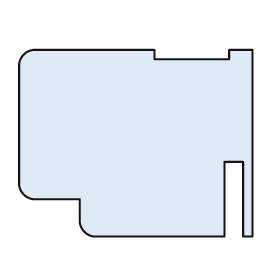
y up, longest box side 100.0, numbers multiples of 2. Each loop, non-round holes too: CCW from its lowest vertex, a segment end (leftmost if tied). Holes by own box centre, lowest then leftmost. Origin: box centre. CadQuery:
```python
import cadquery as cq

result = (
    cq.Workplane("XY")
    .moveTo(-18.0, -40.0)
    .lineTo(38.0, -40.0)
    .lineTo(38.0, -8.0)
    .lineTo(46.0, -8.0)
    .lineTo(46.0, -40.0)
    .lineTo(50.0, -40.0)
    .lineTo(50.0, 40.0)
    .lineTo(40.0, 40.0)
    .lineTo(40.0, 36.0)
    .lineTo(8.0, 36.0)
    .lineTo(8.0, 40.0)
    .lineTo(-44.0, 40.0)
    .threePointArc((-48.0, 38.0), (-50.0, 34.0))
    .lineTo(-50.0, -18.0)
    .threePointArc((-48.0, -22.0), (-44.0, -24.0))
    .lineTo(-24.0, -24.0)
    .lineTo(-24.0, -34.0)
    .threePointArc((-22.0, -38.0), (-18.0, -40.0))
    .close()
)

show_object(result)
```